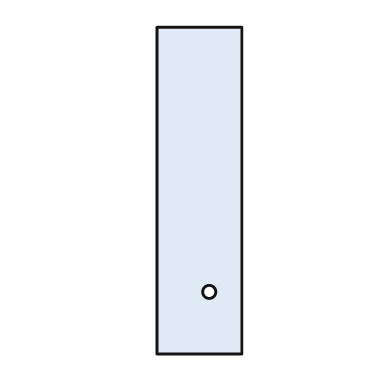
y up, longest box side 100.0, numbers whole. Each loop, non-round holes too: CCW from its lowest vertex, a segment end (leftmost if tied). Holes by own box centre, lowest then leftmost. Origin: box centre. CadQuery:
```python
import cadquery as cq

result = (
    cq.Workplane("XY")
    .moveTo(-13.0, -50.0)
    .lineTo(13.0, -50.0)
    .lineTo(13.0, 50.0)
    .lineTo(-13.0, 50.0)
    .close()
    .moveTo(3.0, -31.0)
    .circle(2.0)
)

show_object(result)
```